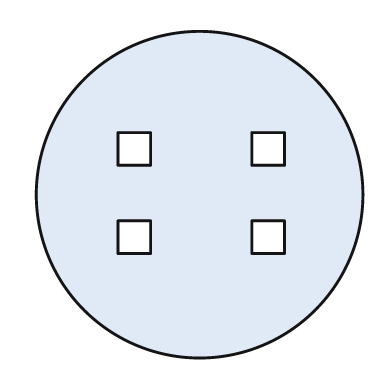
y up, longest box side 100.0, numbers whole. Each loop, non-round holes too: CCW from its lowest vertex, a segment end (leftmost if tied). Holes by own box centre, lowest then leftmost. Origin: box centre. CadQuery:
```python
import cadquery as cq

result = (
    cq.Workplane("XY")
    .moveTo(0.0, 0.0)
    .circle(50.0)
    .moveTo(-25.0, -18.0)
    .lineTo(-15.0, -18.0)
    .lineTo(-15.0, -8.0)
    .lineTo(-25.0, -8.0)
    .close()
    .moveTo(16.0, -18.0)
    .lineTo(26.0, -18.0)
    .lineTo(26.0, -8.0)
    .lineTo(16.0, -8.0)
    .close()
    .moveTo(-25.0, 9.0)
    .lineTo(-15.0, 9.0)
    .lineTo(-15.0, 19.0)
    .lineTo(-25.0, 19.0)
    .close()
    .moveTo(16.0, 9.0)
    .lineTo(26.0, 9.0)
    .lineTo(26.0, 19.0)
    .lineTo(16.0, 19.0)
    .close()
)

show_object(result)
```